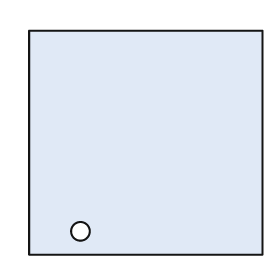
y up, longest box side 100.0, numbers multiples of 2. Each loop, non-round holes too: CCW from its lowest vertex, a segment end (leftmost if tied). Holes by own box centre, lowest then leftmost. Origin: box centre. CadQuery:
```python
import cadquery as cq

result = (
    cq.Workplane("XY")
    .moveTo(-50.0, -48.0)
    .lineTo(50.0, -48.0)
    .lineTo(50.0, 48.0)
    .lineTo(-50.0, 48.0)
    .close()
    .moveTo(-28.0, -38.0)
    .circle(4.0)
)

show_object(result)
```